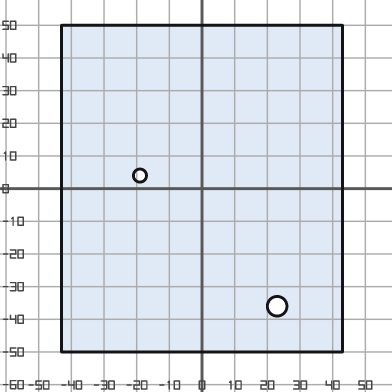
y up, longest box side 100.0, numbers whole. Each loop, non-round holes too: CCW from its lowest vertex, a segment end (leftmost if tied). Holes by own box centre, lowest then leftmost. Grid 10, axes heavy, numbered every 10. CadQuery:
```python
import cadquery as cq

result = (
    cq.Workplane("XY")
    .moveTo(-43.0, -50.0)
    .lineTo(43.0, -50.0)
    .lineTo(43.0, 50.0)
    .lineTo(-43.0, 50.0)
    .close()
    .moveTo(23.0, -36.0)
    .circle(3.0)
    .moveTo(-19.0, 4.0)
    .circle(2.0)
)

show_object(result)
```